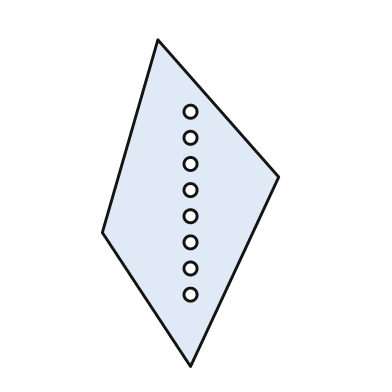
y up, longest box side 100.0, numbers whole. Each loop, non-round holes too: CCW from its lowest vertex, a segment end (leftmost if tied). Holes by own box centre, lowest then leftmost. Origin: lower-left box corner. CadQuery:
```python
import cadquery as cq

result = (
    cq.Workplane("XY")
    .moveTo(27.0, 0.0)
    .lineTo(54.0, 58.0)
    .lineTo(17.0, 100.0)
    .lineTo(0.0, 41.0)
    .close()
    .moveTo(27.0, 22.0)
    .circle(2.0)
    .moveTo(27.0, 30.0)
    .circle(2.0)
    .moveTo(27.0, 38.0)
    .circle(2.0)
    .moveTo(27.0, 46.0)
    .circle(2.0)
    .moveTo(27.0, 54.0)
    .circle(2.0)
    .moveTo(27.0, 62.0)
    .circle(2.0)
    .moveTo(27.0, 70.0)
    .circle(2.0)
    .moveTo(27.0, 78.0)
    .circle(2.0)
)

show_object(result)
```